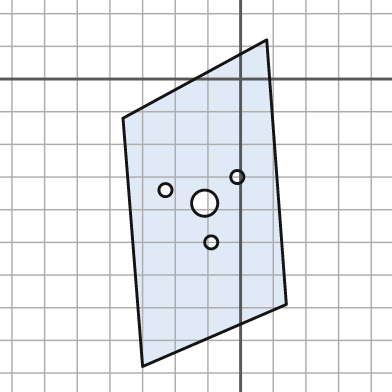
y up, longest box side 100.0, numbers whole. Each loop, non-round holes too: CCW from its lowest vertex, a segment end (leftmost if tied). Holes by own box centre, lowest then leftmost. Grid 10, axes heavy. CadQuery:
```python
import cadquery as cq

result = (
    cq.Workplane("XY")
    .moveTo(-30.0, -88.0)
    .lineTo(14.0, -69.0)
    .lineTo(8.0, 12.0)
    .lineTo(-36.0, -12.0)
    .close()
    .moveTo(-9.0, -50.0)
    .circle(2.0)
    .moveTo(-11.0, -38.0)
    .circle(4.0)
    .moveTo(-23.0, -34.0)
    .circle(2.0)
    .moveTo(-1.0, -30.0)
    .circle(2.0)
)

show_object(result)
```